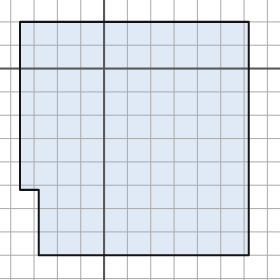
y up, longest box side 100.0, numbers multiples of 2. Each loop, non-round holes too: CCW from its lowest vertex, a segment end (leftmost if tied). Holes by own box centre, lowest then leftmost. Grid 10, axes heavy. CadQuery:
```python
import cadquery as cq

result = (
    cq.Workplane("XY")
    .moveTo(-28.0, -80.0)
    .lineTo(62.0, -80.0)
    .lineTo(62.0, 20.0)
    .lineTo(-36.0, 20.0)
    .lineTo(-36.0, -52.0)
    .lineTo(-28.0, -52.0)
    .close()
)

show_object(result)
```